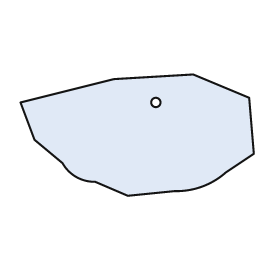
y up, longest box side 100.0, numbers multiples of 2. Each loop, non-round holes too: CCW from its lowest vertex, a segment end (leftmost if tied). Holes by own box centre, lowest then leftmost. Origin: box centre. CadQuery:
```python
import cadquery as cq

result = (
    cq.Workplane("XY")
    .moveTo(-4.0, -26.0)
    .lineTo(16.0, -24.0)
    .threePointArc((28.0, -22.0), (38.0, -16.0))
    .lineTo(50.0, -8.0)
    .lineTo(48.0, 16.0)
    .lineTo(24.0, 26.0)
    .lineTo(-10.0, 24.0)
    .lineTo(-50.0, 14.0)
    .lineTo(-44.0, -2.0)
    .lineTo(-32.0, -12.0)
    .threePointArc((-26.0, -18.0), (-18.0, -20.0))
    .close()
    .moveTo(8.0, 14.0)
    .circle(2.0)
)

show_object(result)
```